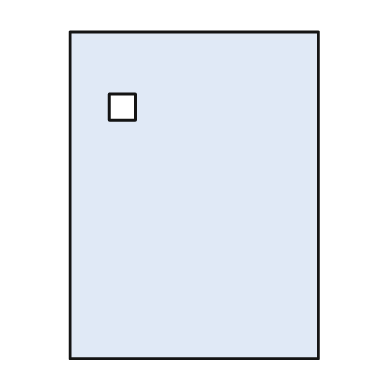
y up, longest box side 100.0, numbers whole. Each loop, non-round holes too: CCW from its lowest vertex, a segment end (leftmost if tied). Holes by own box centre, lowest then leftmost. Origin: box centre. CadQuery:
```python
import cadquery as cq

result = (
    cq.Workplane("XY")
    .moveTo(-38.0, -50.0)
    .lineTo(38.0, -50.0)
    .lineTo(38.0, 50.0)
    .lineTo(-38.0, 50.0)
    .close()
    .moveTo(-26.0, 23.0)
    .lineTo(-18.0, 23.0)
    .lineTo(-18.0, 31.0)
    .lineTo(-26.0, 31.0)
    .close()
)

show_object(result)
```